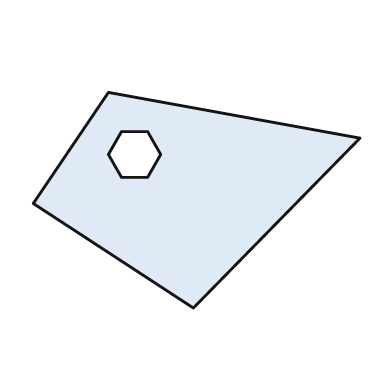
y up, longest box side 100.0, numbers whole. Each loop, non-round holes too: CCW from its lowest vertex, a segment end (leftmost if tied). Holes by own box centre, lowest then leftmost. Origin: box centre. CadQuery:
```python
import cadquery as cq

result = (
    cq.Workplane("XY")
    .moveTo(-1.0, -33.0)
    .lineTo(50.0, 19.0)
    .lineTo(-27.0, 33.0)
    .lineTo(-50.0, -1.0)
    .close()
    .moveTo(-23.0, 7.0)
    .lineTo(-15.0, 7.0)
    .lineTo(-11.0, 14.0)
    .lineTo(-15.0, 21.0)
    .lineTo(-23.0, 21.0)
    .lineTo(-27.0, 14.0)
    .close()
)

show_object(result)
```